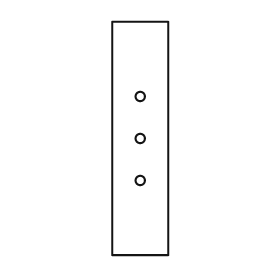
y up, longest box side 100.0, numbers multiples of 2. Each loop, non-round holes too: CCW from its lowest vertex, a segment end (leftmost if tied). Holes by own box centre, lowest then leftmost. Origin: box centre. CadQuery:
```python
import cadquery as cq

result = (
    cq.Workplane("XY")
    .moveTo(-12.0, -50.0)
    .lineTo(12.0, -50.0)
    .lineTo(12.0, 50.0)
    .lineTo(-12.0, 50.0)
    .close()
    .moveTo(0.0, -18.0)
    .circle(2.0)
    .moveTo(0.0, 0.0)
    .circle(2.0)
    .moveTo(0.0, 18.0)
    .circle(2.0)
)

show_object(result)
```